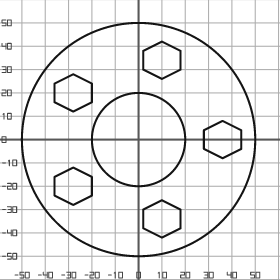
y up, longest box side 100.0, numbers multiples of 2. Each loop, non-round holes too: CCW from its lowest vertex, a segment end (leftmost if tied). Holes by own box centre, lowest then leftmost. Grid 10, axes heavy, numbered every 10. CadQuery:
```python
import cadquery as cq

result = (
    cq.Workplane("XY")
    .moveTo(0.0, 0.0)
    .circle(50.0)
    .moveTo(10.0, -42.0)
    .lineTo(18.0, -38.0)
    .lineTo(18.0, -30.0)
    .lineTo(10.0, -26.0)
    .lineTo(2.0, -30.0)
    .lineTo(2.0, -38.0)
    .close()
    .moveTo(-28.0, -28.0)
    .lineTo(-20.0, -24.0)
    .lineTo(-20.0, -16.0)
    .lineTo(-28.0, -12.0)
    .lineTo(-36.0, -16.0)
    .lineTo(-36.0, -24.0)
    .close()
    .moveTo(0.0, 0.0)
    .circle(20.0)
    .moveTo(36.0, -8.0)
    .lineTo(44.0, -4.0)
    .lineTo(44.0, 4.0)
    .lineTo(36.0, 8.0)
    .lineTo(28.0, 4.0)
    .lineTo(28.0, -4.0)
    .close()
    .moveTo(-28.0, 12.0)
    .lineTo(-20.0, 16.0)
    .lineTo(-20.0, 24.0)
    .lineTo(-28.0, 28.0)
    .lineTo(-36.0, 24.0)
    .lineTo(-36.0, 16.0)
    .close()
    .moveTo(10.0, 26.0)
    .lineTo(18.0, 30.0)
    .lineTo(18.0, 38.0)
    .lineTo(10.0, 42.0)
    .lineTo(2.0, 38.0)
    .lineTo(2.0, 30.0)
    .close()
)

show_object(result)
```